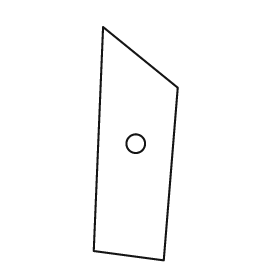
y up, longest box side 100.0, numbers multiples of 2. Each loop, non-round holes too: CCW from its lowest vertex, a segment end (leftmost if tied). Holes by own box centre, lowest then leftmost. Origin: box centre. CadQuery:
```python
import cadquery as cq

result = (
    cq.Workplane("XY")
    .moveTo(12.0, -50.0)
    .lineTo(18.0, 24.0)
    .lineTo(-14.0, 50.0)
    .lineTo(-18.0, -46.0)
    .close()
    .moveTo(0.0, 0.0)
    .circle(4.0)
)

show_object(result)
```